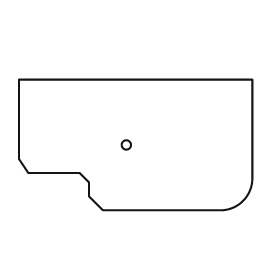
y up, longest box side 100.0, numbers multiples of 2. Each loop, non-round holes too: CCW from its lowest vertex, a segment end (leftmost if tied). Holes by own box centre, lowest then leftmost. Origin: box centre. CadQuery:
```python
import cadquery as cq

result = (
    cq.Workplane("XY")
    .moveTo(-14.0, -28.0)
    .lineTo(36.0, -28.0)
    .threePointArc((46.0, -24.0), (50.0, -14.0))
    .lineTo(50.0, 28.0)
    .lineTo(-50.0, 28.0)
    .lineTo(-50.0, -6.0)
    .lineTo(-46.0, -12.0)
    .lineTo(-24.0, -12.0)
    .lineTo(-20.0, -16.0)
    .lineTo(-20.0, -22.0)
    .close()
    .moveTo(-4.0, 0.0)
    .circle(2.0)
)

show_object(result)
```